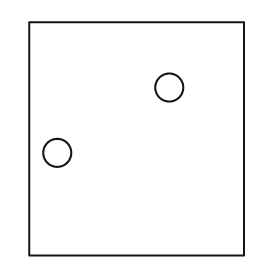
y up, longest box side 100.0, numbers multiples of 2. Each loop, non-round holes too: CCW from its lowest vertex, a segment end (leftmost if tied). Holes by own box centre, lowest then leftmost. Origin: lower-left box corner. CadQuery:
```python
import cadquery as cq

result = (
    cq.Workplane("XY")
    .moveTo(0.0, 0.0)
    .lineTo(92.0, 0.0)
    .lineTo(92.0, 100.0)
    .lineTo(0.0, 100.0)
    .close()
    .moveTo(12.0, 44.0)
    .circle(6.0)
    .moveTo(60.0, 72.0)
    .circle(6.0)
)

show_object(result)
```